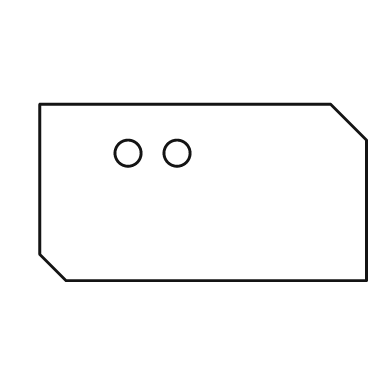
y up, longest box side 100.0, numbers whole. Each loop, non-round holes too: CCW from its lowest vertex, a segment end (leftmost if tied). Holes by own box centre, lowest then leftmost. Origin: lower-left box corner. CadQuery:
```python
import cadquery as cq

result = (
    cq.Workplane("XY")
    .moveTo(8.0, 0.0)
    .lineTo(100.0, 0.0)
    .lineTo(100.0, 43.0)
    .lineTo(89.0, 54.0)
    .lineTo(0.0, 54.0)
    .lineTo(0.0, 8.0)
    .close()
    .moveTo(27.0, 39.0)
    .circle(4.0)
    .moveTo(42.0, 39.0)
    .circle(4.0)
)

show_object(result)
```